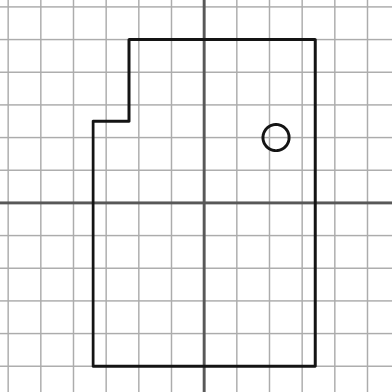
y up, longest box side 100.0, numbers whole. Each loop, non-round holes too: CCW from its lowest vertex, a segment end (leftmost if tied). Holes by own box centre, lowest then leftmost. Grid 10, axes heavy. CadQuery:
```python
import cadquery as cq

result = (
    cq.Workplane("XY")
    .moveTo(-34.0, -50.0)
    .lineTo(34.0, -50.0)
    .lineTo(34.0, 50.0)
    .lineTo(-23.0, 50.0)
    .lineTo(-23.0, 25.0)
    .lineTo(-34.0, 25.0)
    .close()
    .moveTo(22.0, 20.0)
    .circle(4.0)
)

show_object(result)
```